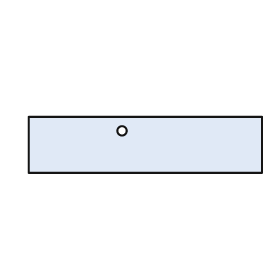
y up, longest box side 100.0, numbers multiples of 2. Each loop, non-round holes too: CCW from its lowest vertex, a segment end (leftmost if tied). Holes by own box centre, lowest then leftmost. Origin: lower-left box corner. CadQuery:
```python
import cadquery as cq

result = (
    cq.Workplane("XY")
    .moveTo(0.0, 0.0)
    .lineTo(100.0, 0.0)
    .lineTo(100.0, 24.0)
    .lineTo(0.0, 24.0)
    .close()
    .moveTo(40.0, 18.0)
    .circle(2.0)
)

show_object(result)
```